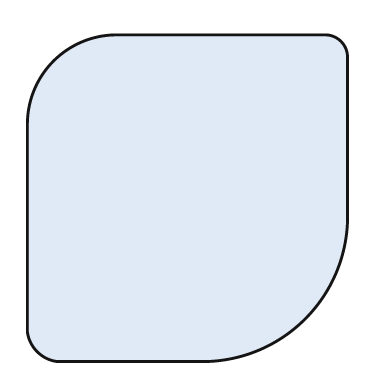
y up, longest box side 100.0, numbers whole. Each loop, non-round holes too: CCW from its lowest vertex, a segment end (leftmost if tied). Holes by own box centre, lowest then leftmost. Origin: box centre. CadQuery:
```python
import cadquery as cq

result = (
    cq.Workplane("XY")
    .moveTo(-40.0, -50.0)
    .lineTo(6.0, -50.0)
    .threePointArc((36.0, -37.0), (49.0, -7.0))
    .lineTo(49.0, 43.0)
    .threePointArc((47.0, 48.0), (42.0, 50.0))
    .lineTo(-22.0, 50.0)
    .threePointArc((-41.0, 42.0), (-49.0, 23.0))
    .lineTo(-49.0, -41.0)
    .threePointArc((-46.0, -47.0), (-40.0, -50.0))
    .close()
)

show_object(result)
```